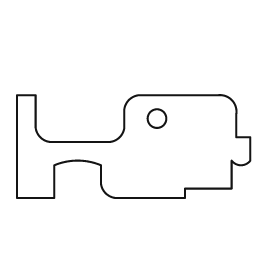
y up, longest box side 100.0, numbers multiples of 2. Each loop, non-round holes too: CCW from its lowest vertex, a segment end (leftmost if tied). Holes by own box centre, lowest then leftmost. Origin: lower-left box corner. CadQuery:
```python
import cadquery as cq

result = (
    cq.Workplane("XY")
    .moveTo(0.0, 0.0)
    .lineTo(16.0, 0.0)
    .lineTo(16.0, 14.0)
    .threePointArc((26.0, 16.0), (36.0, 14.0))
    .lineTo(36.0, 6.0)
    .threePointArc((38.0, 2.0), (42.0, 0.0))
    .lineTo(72.0, 0.0)
    .lineTo(72.0, 4.0)
    .lineTo(92.0, 4.0)
    .lineTo(92.0, 16.0)
    .threePointArc((96.0, 14.0), (100.0, 16.0))
    .lineTo(100.0, 26.0)
    .lineTo(94.0, 26.0)
    .lineTo(94.0, 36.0)
    .threePointArc((92.0, 42.0), (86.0, 44.0))
    .lineTo(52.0, 44.0)
    .threePointArc((48.0, 42.0), (46.0, 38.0))
    .lineTo(46.0, 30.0)
    .threePointArc((44.0, 26.0), (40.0, 24.0))
    .lineTo(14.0, 24.0)
    .threePointArc((10.0, 26.0), (8.0, 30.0))
    .lineTo(8.0, 44.0)
    .lineTo(0.0, 44.0)
    .close()
    .moveTo(60.0, 34.0)
    .circle(4.0)
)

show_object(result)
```